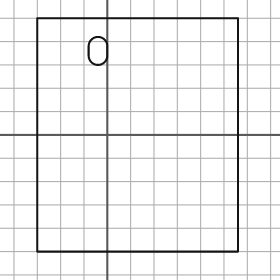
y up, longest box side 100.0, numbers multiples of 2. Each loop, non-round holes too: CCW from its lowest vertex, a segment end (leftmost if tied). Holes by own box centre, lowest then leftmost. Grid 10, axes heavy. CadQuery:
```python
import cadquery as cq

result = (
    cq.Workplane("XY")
    .moveTo(-30.0, -50.0)
    .lineTo(56.0, -50.0)
    .lineTo(56.0, 50.0)
    .lineTo(-30.0, 50.0)
    .close()
    .moveTo(-8.0, 34.0)
    .threePointArc((-4.0, 30.0), (0.0, 34.0))
    .lineTo(0.0, 38.0)
    .threePointArc((-4.0, 42.0), (-8.0, 38.0))
    .close()
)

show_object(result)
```